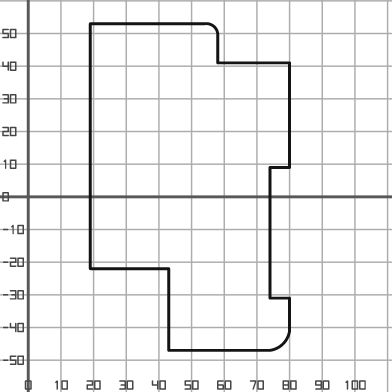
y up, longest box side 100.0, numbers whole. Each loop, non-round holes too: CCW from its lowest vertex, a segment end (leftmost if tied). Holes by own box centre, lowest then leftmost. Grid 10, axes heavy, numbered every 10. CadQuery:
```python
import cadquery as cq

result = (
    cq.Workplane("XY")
    .moveTo(43.0, -47.0)
    .lineTo(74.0, -47.0)
    .threePointArc((78.0, -45.0), (80.0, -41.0))
    .lineTo(80.0, -31.0)
    .lineTo(74.0, -31.0)
    .lineTo(74.0, 9.0)
    .lineTo(80.0, 9.0)
    .lineTo(80.0, 41.0)
    .lineTo(58.0, 41.0)
    .lineTo(58.0, 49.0)
    .threePointArc((57.0, 52.0), (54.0, 53.0))
    .lineTo(19.0, 53.0)
    .lineTo(19.0, -22.0)
    .lineTo(43.0, -22.0)
    .close()
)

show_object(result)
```